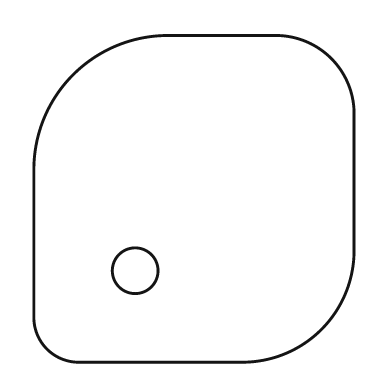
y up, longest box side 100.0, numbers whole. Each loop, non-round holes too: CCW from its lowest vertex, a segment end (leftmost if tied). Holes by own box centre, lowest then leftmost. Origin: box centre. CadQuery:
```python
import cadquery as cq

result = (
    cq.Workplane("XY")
    .moveTo(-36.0, -50.0)
    .lineTo(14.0, -50.0)
    .threePointArc((39.0, -40.0), (49.0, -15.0))
    .lineTo(49.0, 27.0)
    .threePointArc((42.0, 43.0), (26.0, 50.0))
    .lineTo(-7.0, 50.0)
    .threePointArc((-37.0, 38.0), (-49.0, 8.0))
    .lineTo(-49.0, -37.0)
    .threePointArc((-45.0, -46.0), (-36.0, -50.0))
    .close()
    .moveTo(-18.0, -22.0)
    .circle(7.0)
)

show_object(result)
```